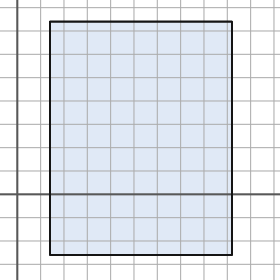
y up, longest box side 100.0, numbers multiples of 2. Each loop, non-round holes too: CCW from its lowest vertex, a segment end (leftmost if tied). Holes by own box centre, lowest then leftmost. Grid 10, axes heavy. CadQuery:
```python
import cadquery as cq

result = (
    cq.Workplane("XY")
    .moveTo(14.0, -26.0)
    .lineTo(92.0, -26.0)
    .lineTo(92.0, 74.0)
    .lineTo(14.0, 74.0)
    .close()
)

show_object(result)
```